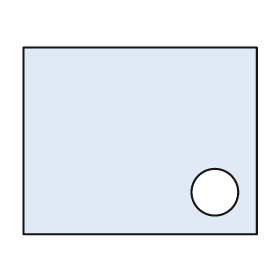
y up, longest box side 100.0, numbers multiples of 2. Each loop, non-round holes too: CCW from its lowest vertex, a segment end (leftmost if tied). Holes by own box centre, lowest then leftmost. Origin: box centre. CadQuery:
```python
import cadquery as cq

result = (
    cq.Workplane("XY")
    .moveTo(-50.0, -40.0)
    .lineTo(50.0, -40.0)
    .lineTo(50.0, 40.0)
    .lineTo(-50.0, 40.0)
    .close()
    .moveTo(32.0, -22.0)
    .circle(10.0)
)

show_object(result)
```